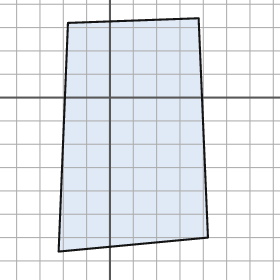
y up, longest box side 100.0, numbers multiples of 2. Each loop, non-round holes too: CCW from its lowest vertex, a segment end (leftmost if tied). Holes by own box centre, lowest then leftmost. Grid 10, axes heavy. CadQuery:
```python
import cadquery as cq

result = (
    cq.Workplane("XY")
    .moveTo(-22.0, -66.0)
    .lineTo(42.0, -60.0)
    .lineTo(38.0, 34.0)
    .lineTo(-18.0, 32.0)
    .close()
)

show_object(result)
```